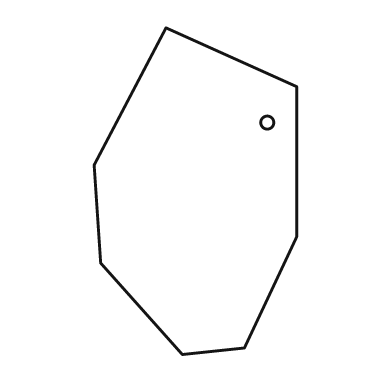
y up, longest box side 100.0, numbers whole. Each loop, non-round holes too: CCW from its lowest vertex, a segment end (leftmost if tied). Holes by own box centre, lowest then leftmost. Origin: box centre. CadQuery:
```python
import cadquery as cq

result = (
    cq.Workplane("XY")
    .moveTo(-4.0, -50.0)
    .lineTo(15.0, -48.0)
    .lineTo(31.0, -14.0)
    .lineTo(31.0, 32.0)
    .lineTo(-9.0, 50.0)
    .lineTo(-31.0, 8.0)
    .lineTo(-29.0, -22.0)
    .close()
    .moveTo(22.0, 21.0)
    .circle(2.0)
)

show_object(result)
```